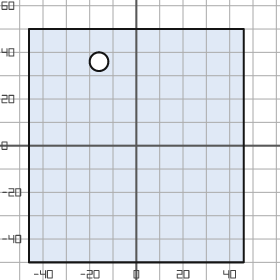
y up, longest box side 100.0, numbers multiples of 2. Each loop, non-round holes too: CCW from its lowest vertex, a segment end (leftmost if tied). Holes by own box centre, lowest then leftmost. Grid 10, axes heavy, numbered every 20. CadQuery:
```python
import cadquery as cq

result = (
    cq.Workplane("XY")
    .moveTo(-46.0, -50.0)
    .lineTo(46.0, -50.0)
    .lineTo(46.0, 50.0)
    .lineTo(-46.0, 50.0)
    .close()
    .moveTo(-16.0, 36.0)
    .circle(4.0)
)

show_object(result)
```